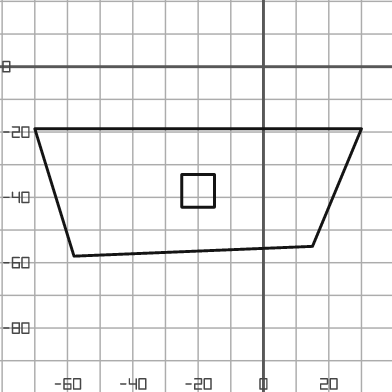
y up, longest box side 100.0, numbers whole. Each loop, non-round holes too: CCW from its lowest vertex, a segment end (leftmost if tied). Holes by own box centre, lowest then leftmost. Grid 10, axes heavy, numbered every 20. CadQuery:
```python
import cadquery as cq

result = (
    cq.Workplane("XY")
    .moveTo(-58.0, -58.0)
    .lineTo(15.0, -55.0)
    .lineTo(30.0, -19.0)
    .lineTo(-70.0, -19.0)
    .close()
    .moveTo(-25.0, -43.0)
    .lineTo(-15.0, -43.0)
    .lineTo(-15.0, -33.0)
    .lineTo(-25.0, -33.0)
    .close()
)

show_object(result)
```